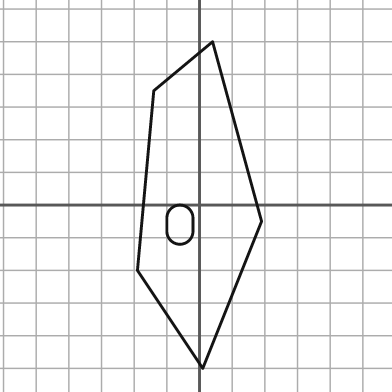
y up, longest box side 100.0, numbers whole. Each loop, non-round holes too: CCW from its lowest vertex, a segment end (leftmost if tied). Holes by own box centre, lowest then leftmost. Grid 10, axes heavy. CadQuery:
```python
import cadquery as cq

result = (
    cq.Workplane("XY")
    .moveTo(1.0, -50.0)
    .lineTo(19.0, -5.0)
    .lineTo(4.0, 50.0)
    .lineTo(-14.0, 35.0)
    .lineTo(-19.0, -20.0)
    .close()
    .moveTo(-10.0, -8.0)
    .threePointArc((-6.0, -12.0), (-2.0, -8.0))
    .lineTo(-2.0, -4.0)
    .threePointArc((-6.0, 0.0), (-10.0, -4.0))
    .close()
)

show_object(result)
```